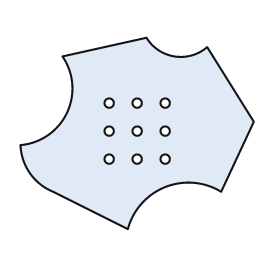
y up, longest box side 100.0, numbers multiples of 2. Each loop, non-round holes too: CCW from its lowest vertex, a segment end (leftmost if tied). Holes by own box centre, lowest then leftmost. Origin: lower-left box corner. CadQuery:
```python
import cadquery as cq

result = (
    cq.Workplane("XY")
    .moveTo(46.0, 0.0)
    .threePointArc((62.0, 18.0), (86.0, 16.0))
    .lineTo(100.0, 46.0)
    .lineTo(80.0, 78.0)
    .threePointArc((66.0, 74.0), (54.0, 82.0))
    .lineTo(18.0, 74.0)
    .threePointArc((20.0, 50.0), (0.0, 36.0))
    .threePointArc((4.0, 24.0), (14.0, 16.0))
    .close()
    .moveTo(38.0, 30.0)
    .circle(2.0)
    .moveTo(50.0, 30.0)
    .circle(2.0)
    .moveTo(62.0, 30.0)
    .circle(2.0)
    .moveTo(38.0, 42.0)
    .circle(2.0)
    .moveTo(50.0, 42.0)
    .circle(2.0)
    .moveTo(62.0, 42.0)
    .circle(2.0)
    .moveTo(38.0, 54.0)
    .circle(2.0)
    .moveTo(50.0, 54.0)
    .circle(2.0)
    .moveTo(62.0, 54.0)
    .circle(2.0)
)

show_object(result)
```